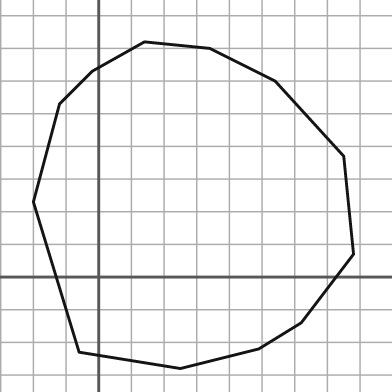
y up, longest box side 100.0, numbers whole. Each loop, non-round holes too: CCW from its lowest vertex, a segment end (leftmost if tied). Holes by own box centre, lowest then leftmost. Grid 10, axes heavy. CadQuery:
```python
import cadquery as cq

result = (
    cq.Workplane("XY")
    .moveTo(25.0, -28.0)
    .lineTo(49.0, -22.0)
    .lineTo(62.0, -14.0)
    .lineTo(78.0, 7.0)
    .lineTo(75.0, 37.0)
    .lineTo(54.0, 60.0)
    .lineTo(34.0, 70.0)
    .lineTo(14.0, 72.0)
    .lineTo(-2.0, 63.0)
    .lineTo(-12.0, 53.0)
    .lineTo(-20.0, 23.0)
    .lineTo(-6.0, -23.0)
    .close()
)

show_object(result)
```